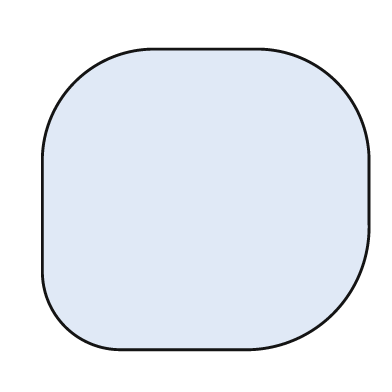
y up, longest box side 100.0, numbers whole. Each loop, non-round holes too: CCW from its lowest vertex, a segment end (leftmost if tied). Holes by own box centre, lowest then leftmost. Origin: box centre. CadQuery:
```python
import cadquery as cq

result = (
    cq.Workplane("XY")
    .moveTo(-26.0, -46.0)
    .lineTo(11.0, -46.0)
    .threePointArc((39.0, -35.0), (50.0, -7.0))
    .lineTo(50.0, 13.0)
    .threePointArc((40.0, 36.0), (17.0, 46.0))
    .lineTo(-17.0, 46.0)
    .threePointArc((-40.0, 36.0), (-50.0, 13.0))
    .lineTo(-50.0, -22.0)
    .threePointArc((-43.0, -39.0), (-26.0, -46.0))
    .close()
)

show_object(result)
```